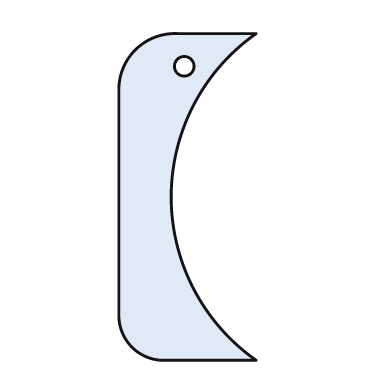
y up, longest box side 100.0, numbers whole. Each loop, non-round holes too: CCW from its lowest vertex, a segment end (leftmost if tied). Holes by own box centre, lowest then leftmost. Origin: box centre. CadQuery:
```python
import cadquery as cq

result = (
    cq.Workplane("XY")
    .moveTo(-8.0, -50.0)
    .lineTo(21.0, -50.0)
    .threePointArc((-5.0, 0.0), (21.0, 50.0))
    .lineTo(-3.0, 50.0)
    .threePointArc((-16.0, 45.0), (-21.0, 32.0))
    .lineTo(-21.0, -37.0)
    .threePointArc((-17.0, -46.0), (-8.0, -50.0))
    .close()
    .moveTo(-1.0, 40.0)
    .circle(3.0)
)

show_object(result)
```